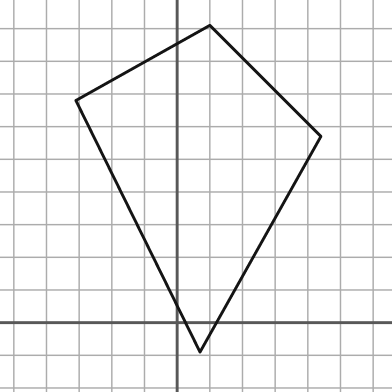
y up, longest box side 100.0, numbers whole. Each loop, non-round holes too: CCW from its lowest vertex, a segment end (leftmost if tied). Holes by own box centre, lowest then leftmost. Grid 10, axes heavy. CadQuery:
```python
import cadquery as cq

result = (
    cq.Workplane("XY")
    .moveTo(7.0, -9.0)
    .lineTo(44.0, 57.0)
    .lineTo(10.0, 91.0)
    .lineTo(-31.0, 68.0)
    .close()
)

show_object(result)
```